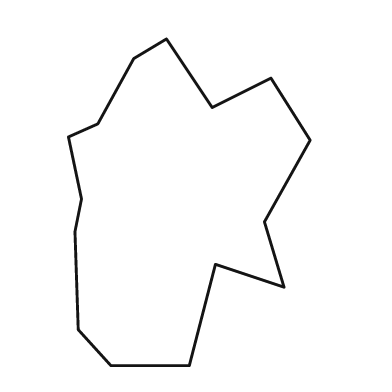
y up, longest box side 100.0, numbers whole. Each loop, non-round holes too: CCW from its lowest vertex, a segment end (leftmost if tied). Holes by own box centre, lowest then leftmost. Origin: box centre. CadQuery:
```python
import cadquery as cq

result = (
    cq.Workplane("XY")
    .moveTo(-24.0, -50.0)
    .lineTo(0.0, -50.0)
    .lineTo(8.0, -19.0)
    .lineTo(29.0, -26.0)
    .lineTo(23.0, -6.0)
    .lineTo(37.0, 19.0)
    .lineTo(25.0, 38.0)
    .lineTo(7.0, 29.0)
    .lineTo(-7.0, 50.0)
    .lineTo(-17.0, 44.0)
    .lineTo(-28.0, 24.0)
    .lineTo(-37.0, 20.0)
    .lineTo(-33.0, 1.0)
    .lineTo(-35.0, -9.0)
    .lineTo(-34.0, -39.0)
    .close()
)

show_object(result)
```